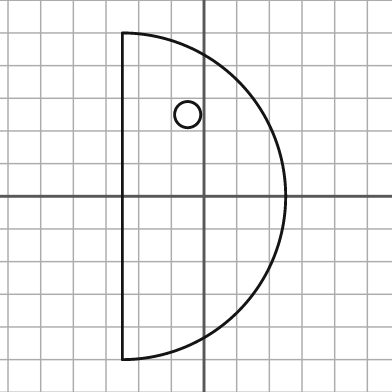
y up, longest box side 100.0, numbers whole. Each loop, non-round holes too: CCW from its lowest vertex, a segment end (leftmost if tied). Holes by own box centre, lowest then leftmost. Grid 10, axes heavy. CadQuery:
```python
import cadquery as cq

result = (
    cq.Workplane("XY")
    .moveTo(-25.0, -50.0)
    .threePointArc((25.0, 0.0), (-25.0, 50.0))
    .close()
    .moveTo(-5.0, 25.0)
    .circle(4.0)
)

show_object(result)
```